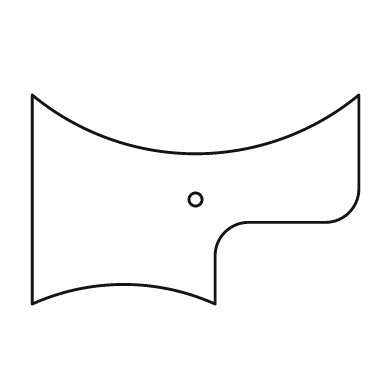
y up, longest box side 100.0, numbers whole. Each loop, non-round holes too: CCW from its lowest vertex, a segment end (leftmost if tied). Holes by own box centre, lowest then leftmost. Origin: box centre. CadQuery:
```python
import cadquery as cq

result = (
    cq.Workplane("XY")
    .moveTo(-50.0, -32.0)
    .threePointArc((-22.0, -26.0), (6.0, -32.0))
    .lineTo(6.0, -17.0)
    .threePointArc((9.0, -10.0), (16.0, -7.0))
    .lineTo(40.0, -7.0)
    .threePointArc((47.0, -4.0), (50.0, 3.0))
    .lineTo(50.0, 32.0)
    .threePointArc((0.0, 14.0), (-50.0, 32.0))
    .close()
    .moveTo(0.0, 0.0)
    .circle(2.0)
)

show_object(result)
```